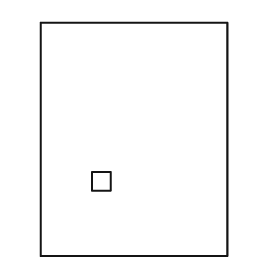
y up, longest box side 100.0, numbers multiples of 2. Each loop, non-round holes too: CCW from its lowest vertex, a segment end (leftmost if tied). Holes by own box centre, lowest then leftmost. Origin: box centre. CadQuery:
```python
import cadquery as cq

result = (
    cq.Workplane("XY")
    .moveTo(-40.0, -50.0)
    .lineTo(40.0, -50.0)
    .lineTo(40.0, 50.0)
    .lineTo(-40.0, 50.0)
    .close()
    .moveTo(-18.0, -22.0)
    .lineTo(-10.0, -22.0)
    .lineTo(-10.0, -14.0)
    .lineTo(-18.0, -14.0)
    .close()
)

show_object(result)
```